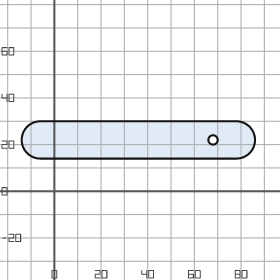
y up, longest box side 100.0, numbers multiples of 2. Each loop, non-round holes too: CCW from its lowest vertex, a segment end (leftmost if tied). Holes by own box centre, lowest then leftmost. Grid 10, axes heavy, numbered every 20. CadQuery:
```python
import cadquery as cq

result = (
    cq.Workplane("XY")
    .moveTo(-6.0, 14.0)
    .lineTo(78.0, 14.0)
    .threePointArc((86.0, 22.0), (78.0, 30.0))
    .lineTo(-6.0, 30.0)
    .threePointArc((-14.0, 22.0), (-6.0, 14.0))
    .close()
    .moveTo(68.0, 22.0)
    .circle(2.0)
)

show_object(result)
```